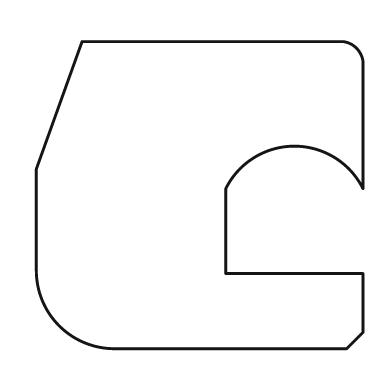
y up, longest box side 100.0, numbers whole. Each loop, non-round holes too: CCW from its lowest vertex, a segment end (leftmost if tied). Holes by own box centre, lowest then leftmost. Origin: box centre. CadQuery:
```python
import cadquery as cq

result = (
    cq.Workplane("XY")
    .moveTo(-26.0, -47.0)
    .lineTo(45.0, -47.0)
    .lineTo(50.0, -42.0)
    .lineTo(50.0, -24.0)
    .lineTo(8.0, -24.0)
    .lineTo(8.0, 2.0)
    .threePointArc((29.0, 15.0), (50.0, 2.0))
    .lineTo(50.0, 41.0)
    .threePointArc((48.0, 45.0), (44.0, 47.0))
    .lineTo(-36.0, 47.0)
    .lineTo(-50.0, 8.0)
    .lineTo(-50.0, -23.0)
    .threePointArc((-43.0, -40.0), (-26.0, -47.0))
    .close()
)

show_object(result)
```